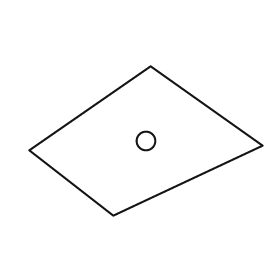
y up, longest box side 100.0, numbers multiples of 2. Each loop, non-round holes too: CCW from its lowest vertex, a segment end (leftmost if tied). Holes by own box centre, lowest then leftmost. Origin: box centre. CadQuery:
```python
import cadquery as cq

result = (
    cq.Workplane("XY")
    .moveTo(-14.0, -32.0)
    .lineTo(50.0, -2.0)
    .lineTo(2.0, 32.0)
    .lineTo(-50.0, -4.0)
    .close()
    .moveTo(0.0, 0.0)
    .circle(4.0)
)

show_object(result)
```